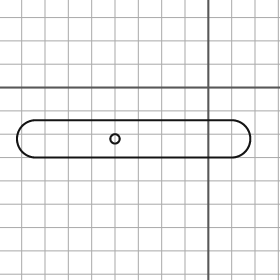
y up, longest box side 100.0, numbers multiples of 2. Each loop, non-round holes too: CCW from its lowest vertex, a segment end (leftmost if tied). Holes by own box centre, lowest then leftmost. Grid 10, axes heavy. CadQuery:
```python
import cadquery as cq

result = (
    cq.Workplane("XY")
    .moveTo(-74.0, -30.0)
    .lineTo(10.0, -30.0)
    .threePointArc((18.0, -22.0), (10.0, -14.0))
    .lineTo(-74.0, -14.0)
    .threePointArc((-82.0, -22.0), (-74.0, -30.0))
    .close()
    .moveTo(-40.0, -22.0)
    .circle(2.0)
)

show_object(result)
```